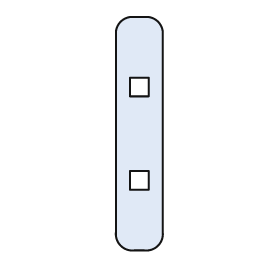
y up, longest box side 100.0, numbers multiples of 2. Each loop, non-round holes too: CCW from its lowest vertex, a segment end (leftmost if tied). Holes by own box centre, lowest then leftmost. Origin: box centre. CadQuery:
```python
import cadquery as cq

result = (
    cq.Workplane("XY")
    .moveTo(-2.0, -50.0)
    .lineTo(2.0, -50.0)
    .threePointArc((8.0, -48.0), (10.0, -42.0))
    .lineTo(10.0, 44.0)
    .threePointArc((8.0, 48.0), (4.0, 50.0))
    .lineTo(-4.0, 50.0)
    .threePointArc((-8.0, 48.0), (-10.0, 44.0))
    .lineTo(-10.0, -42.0)
    .threePointArc((-8.0, -48.0), (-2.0, -50.0))
    .close()
    .moveTo(-4.0, -24.0)
    .lineTo(4.0, -24.0)
    .lineTo(4.0, -16.0)
    .lineTo(-4.0, -16.0)
    .close()
    .moveTo(-4.0, 16.0)
    .lineTo(4.0, 16.0)
    .lineTo(4.0, 24.0)
    .lineTo(-4.0, 24.0)
    .close()
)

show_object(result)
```